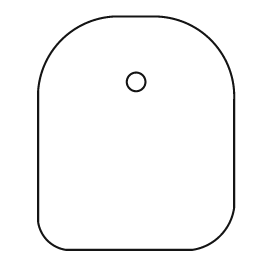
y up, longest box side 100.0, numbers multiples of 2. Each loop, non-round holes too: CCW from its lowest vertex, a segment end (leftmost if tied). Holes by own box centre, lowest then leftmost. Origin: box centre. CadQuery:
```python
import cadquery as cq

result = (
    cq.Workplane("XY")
    .moveTo(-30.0, -50.0)
    .lineTo(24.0, -50.0)
    .threePointArc((36.0, -44.0), (42.0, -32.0))
    .lineTo(42.0, 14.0)
    .threePointArc((32.0, 40.0), (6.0, 50.0))
    .lineTo(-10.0, 50.0)
    .threePointArc((-32.0, 40.0), (-42.0, 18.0))
    .lineTo(-42.0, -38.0)
    .threePointArc((-38.0, -46.0), (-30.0, -50.0))
    .close()
    .moveTo(0.0, 22.0)
    .circle(4.0)
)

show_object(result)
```